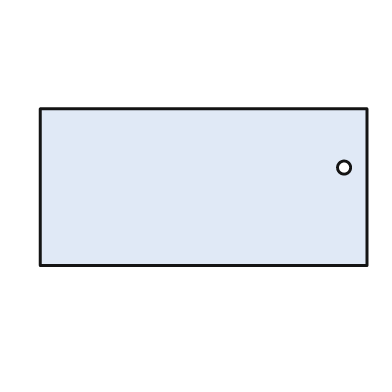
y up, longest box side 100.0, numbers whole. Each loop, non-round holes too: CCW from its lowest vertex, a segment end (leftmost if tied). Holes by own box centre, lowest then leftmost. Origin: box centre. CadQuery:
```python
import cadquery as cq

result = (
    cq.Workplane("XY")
    .moveTo(-50.0, -24.0)
    .lineTo(50.0, -24.0)
    .lineTo(50.0, 24.0)
    .lineTo(-50.0, 24.0)
    .close()
    .moveTo(43.0, 6.0)
    .circle(2.0)
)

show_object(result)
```